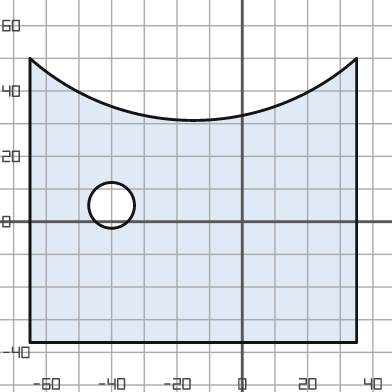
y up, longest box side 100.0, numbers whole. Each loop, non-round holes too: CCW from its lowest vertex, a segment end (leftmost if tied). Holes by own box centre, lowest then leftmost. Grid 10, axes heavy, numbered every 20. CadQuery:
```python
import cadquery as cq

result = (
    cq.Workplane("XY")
    .moveTo(-65.0, -37.0)
    .lineTo(35.0, -37.0)
    .lineTo(35.0, 50.0)
    .threePointArc((-15.0, 31.0), (-65.0, 50.0))
    .close()
    .moveTo(-40.0, 5.0)
    .circle(7.0)
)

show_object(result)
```